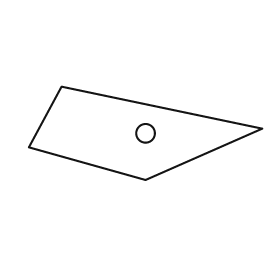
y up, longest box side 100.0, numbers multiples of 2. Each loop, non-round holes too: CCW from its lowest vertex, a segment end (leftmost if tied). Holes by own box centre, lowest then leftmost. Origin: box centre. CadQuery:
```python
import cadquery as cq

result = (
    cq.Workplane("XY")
    .moveTo(0.0, -20.0)
    .lineTo(50.0, 2.0)
    .lineTo(-36.0, 20.0)
    .lineTo(-50.0, -6.0)
    .close()
    .moveTo(0.0, 0.0)
    .circle(4.0)
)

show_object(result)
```